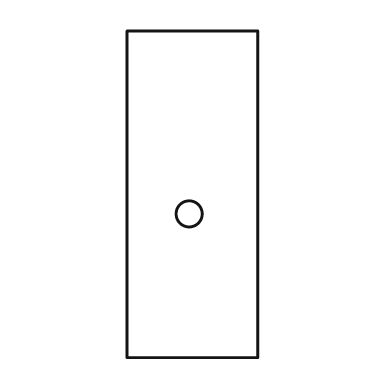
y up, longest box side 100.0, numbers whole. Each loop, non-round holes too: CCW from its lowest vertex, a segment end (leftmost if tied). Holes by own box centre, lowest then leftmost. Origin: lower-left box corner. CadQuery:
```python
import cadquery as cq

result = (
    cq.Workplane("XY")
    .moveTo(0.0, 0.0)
    .lineTo(40.0, 0.0)
    .lineTo(40.0, 100.0)
    .lineTo(0.0, 100.0)
    .close()
    .moveTo(19.0, 44.0)
    .circle(4.0)
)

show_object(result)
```